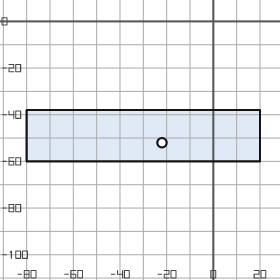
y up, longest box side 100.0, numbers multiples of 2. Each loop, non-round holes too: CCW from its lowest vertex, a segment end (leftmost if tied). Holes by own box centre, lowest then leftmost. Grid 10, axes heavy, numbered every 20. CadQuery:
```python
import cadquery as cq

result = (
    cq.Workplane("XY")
    .moveTo(-80.0, -60.0)
    .lineTo(20.0, -60.0)
    .lineTo(20.0, -38.0)
    .lineTo(-80.0, -38.0)
    .close()
    .moveTo(-22.0, -52.0)
    .circle(2.0)
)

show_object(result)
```